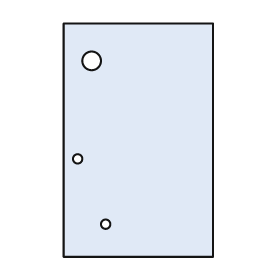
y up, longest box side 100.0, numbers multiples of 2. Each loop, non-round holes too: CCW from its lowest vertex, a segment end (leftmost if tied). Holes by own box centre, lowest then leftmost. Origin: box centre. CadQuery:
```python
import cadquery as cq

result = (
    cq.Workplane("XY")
    .moveTo(-32.0, -50.0)
    .lineTo(32.0, -50.0)
    .lineTo(32.0, 50.0)
    .lineTo(-32.0, 50.0)
    .close()
    .moveTo(-14.0, -36.0)
    .circle(2.0)
    .moveTo(-26.0, -8.0)
    .circle(2.0)
    .moveTo(-20.0, 34.0)
    .circle(4.0)
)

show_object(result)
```